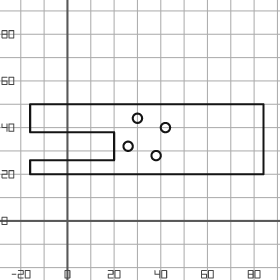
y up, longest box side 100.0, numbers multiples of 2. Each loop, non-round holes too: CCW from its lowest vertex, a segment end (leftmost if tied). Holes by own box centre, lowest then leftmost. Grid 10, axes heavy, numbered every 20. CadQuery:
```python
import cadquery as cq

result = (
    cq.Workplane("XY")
    .moveTo(-16.0, 20.0)
    .lineTo(84.0, 20.0)
    .lineTo(84.0, 50.0)
    .lineTo(-16.0, 50.0)
    .lineTo(-16.0, 38.0)
    .lineTo(20.0, 38.0)
    .lineTo(20.0, 26.0)
    .lineTo(-16.0, 26.0)
    .close()
    .moveTo(38.0, 28.0)
    .circle(2.0)
    .moveTo(26.0, 32.0)
    .circle(2.0)
    .moveTo(42.0, 40.0)
    .circle(2.0)
    .moveTo(30.0, 44.0)
    .circle(2.0)
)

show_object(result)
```